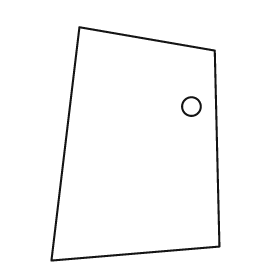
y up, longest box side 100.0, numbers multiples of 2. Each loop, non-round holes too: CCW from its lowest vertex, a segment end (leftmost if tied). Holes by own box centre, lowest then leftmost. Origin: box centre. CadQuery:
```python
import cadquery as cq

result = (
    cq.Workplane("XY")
    .moveTo(-36.0, -50.0)
    .lineTo(36.0, -44.0)
    .lineTo(34.0, 40.0)
    .lineTo(-24.0, 50.0)
    .close()
    .moveTo(24.0, 16.0)
    .circle(4.0)
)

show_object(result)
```